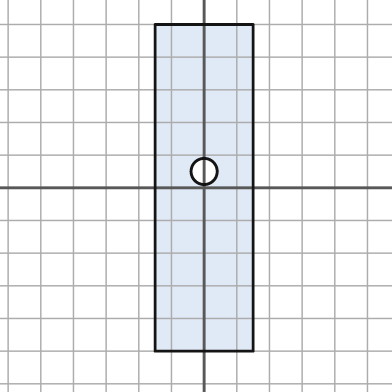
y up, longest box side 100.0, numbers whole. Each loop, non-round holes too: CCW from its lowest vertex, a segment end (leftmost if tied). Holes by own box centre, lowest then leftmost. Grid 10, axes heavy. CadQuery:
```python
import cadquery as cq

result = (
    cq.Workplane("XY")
    .moveTo(-15.0, -50.0)
    .lineTo(15.0, -50.0)
    .lineTo(15.0, 50.0)
    .lineTo(-15.0, 50.0)
    .close()
    .moveTo(0.0, 5.0)
    .circle(4.0)
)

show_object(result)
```